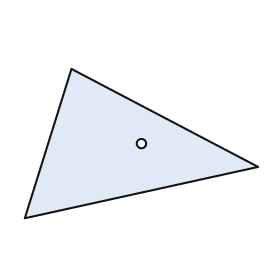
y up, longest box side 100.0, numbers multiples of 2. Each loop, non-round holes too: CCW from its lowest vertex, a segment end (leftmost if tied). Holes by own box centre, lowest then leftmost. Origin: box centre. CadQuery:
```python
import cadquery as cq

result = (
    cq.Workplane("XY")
    .moveTo(-50.0, -32.0)
    .lineTo(50.0, -10.0)
    .lineTo(-30.0, 32.0)
    .close()
    .moveTo(0.0, 0.0)
    .circle(2.0)
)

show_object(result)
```